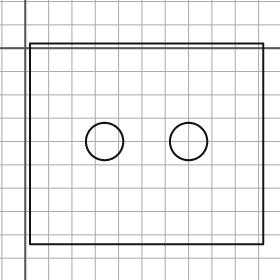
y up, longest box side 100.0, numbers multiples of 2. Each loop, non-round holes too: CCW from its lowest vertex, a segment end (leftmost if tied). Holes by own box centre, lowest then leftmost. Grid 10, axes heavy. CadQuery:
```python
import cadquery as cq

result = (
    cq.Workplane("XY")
    .moveTo(2.0, -84.0)
    .lineTo(102.0, -84.0)
    .lineTo(102.0, 2.0)
    .lineTo(2.0, 2.0)
    .close()
    .moveTo(34.0, -40.0)
    .circle(8.0)
    .moveTo(70.0, -40.0)
    .circle(8.0)
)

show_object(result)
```